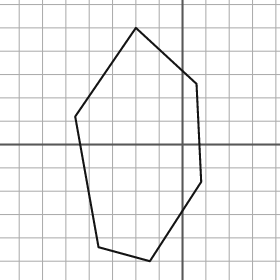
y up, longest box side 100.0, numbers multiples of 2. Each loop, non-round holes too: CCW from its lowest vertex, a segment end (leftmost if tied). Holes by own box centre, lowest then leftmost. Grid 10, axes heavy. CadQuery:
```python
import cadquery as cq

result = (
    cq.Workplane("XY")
    .moveTo(-14.0, -50.0)
    .lineTo(8.0, -16.0)
    .lineTo(6.0, 26.0)
    .lineTo(-20.0, 50.0)
    .lineTo(-46.0, 12.0)
    .lineTo(-36.0, -44.0)
    .close()
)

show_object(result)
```